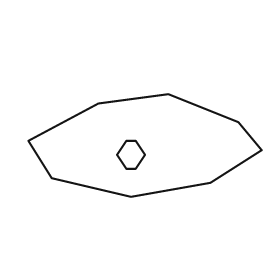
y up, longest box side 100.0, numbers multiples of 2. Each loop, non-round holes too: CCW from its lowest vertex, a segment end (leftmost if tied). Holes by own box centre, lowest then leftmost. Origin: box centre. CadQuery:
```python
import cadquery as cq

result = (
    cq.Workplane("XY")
    .moveTo(-6.0, -22.0)
    .lineTo(28.0, -16.0)
    .lineTo(50.0, -2.0)
    .lineTo(40.0, 10.0)
    .lineTo(10.0, 22.0)
    .lineTo(-20.0, 18.0)
    .lineTo(-50.0, 2.0)
    .lineTo(-40.0, -14.0)
    .close()
    .moveTo(-8.0, -10.0)
    .lineTo(-4.0, -10.0)
    .lineTo(0.0, -4.0)
    .lineTo(-4.0, 2.0)
    .lineTo(-8.0, 2.0)
    .lineTo(-12.0, -4.0)
    .close()
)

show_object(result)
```